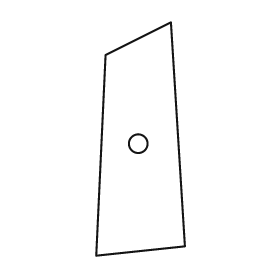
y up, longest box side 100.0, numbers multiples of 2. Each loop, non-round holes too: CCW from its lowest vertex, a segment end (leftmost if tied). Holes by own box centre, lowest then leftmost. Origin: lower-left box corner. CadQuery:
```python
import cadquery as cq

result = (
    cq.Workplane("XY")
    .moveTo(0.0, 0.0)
    .lineTo(38.0, 4.0)
    .lineTo(32.0, 100.0)
    .lineTo(4.0, 86.0)
    .close()
    .moveTo(18.0, 48.0)
    .circle(4.0)
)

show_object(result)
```